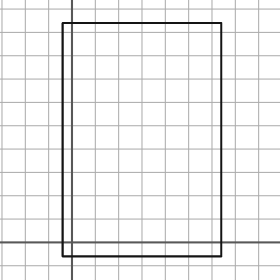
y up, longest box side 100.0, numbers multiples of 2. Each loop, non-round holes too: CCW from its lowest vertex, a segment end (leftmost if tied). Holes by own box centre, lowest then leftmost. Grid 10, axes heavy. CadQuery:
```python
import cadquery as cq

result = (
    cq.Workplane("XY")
    .moveTo(-4.0, -6.0)
    .lineTo(64.0, -6.0)
    .lineTo(64.0, 94.0)
    .lineTo(-4.0, 94.0)
    .close()
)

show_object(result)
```